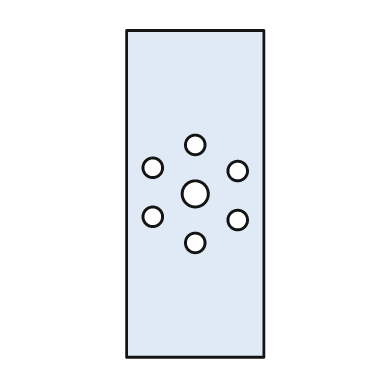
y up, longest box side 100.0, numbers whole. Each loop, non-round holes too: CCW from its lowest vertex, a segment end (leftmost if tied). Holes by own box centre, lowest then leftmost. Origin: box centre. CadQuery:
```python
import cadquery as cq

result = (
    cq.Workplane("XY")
    .moveTo(-21.0, -50.0)
    .lineTo(21.0, -50.0)
    .lineTo(21.0, 50.0)
    .lineTo(-21.0, 50.0)
    .close()
    .moveTo(0.0, -15.0)
    .circle(3.0)
    .moveTo(13.0, -8.0)
    .circle(3.0)
    .moveTo(-13.0, -7.0)
    .circle(3.0)
    .moveTo(0.0, 0.0)
    .circle(4.0)
    .moveTo(13.0, 7.0)
    .circle(3.0)
    .moveTo(-13.0, 8.0)
    .circle(3.0)
    .moveTo(0.0, 15.0)
    .circle(3.0)
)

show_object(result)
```